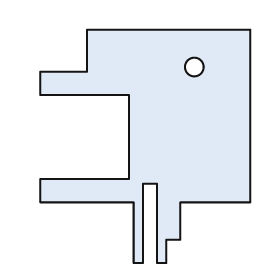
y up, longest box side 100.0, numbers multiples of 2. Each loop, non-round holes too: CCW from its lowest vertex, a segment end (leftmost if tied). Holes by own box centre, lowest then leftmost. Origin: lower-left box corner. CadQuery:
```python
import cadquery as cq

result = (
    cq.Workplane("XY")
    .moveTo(40.0, 0.0)
    .lineTo(44.0, 0.0)
    .lineTo(44.0, 34.0)
    .lineTo(50.0, 34.0)
    .lineTo(50.0, 0.0)
    .lineTo(54.0, 0.0)
    .lineTo(54.0, 10.0)
    .lineTo(60.0, 10.0)
    .lineTo(60.0, 26.0)
    .lineTo(90.0, 26.0)
    .lineTo(90.0, 100.0)
    .lineTo(20.0, 100.0)
    .lineTo(20.0, 82.0)
    .lineTo(0.0, 82.0)
    .lineTo(0.0, 72.0)
    .lineTo(38.0, 72.0)
    .lineTo(38.0, 36.0)
    .lineTo(0.0, 36.0)
    .lineTo(0.0, 26.0)
    .lineTo(40.0, 26.0)
    .close()
    .moveTo(66.0, 84.0)
    .circle(4.0)
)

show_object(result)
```